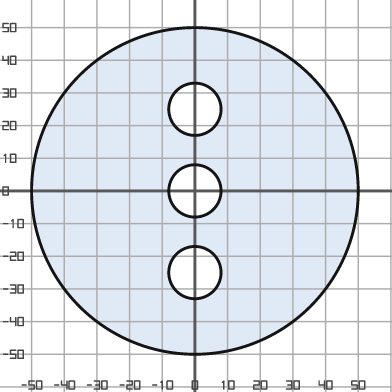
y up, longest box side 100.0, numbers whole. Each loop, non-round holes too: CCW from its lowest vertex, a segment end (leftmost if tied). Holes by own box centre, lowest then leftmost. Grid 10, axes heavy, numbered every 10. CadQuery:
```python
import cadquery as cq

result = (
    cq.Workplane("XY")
    .moveTo(0.0, 0.0)
    .circle(50.0)
    .moveTo(0.0, -25.0)
    .circle(8.0)
    .moveTo(0.0, 0.0)
    .circle(8.0)
    .moveTo(0.0, 25.0)
    .circle(8.0)
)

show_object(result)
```